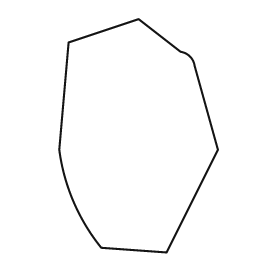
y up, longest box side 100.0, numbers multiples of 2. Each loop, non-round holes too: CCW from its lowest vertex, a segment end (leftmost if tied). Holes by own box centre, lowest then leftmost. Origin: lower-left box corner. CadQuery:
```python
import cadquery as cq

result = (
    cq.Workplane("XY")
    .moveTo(46.0, 0.0)
    .lineTo(68.0, 44.0)
    .lineTo(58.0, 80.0)
    .threePointArc((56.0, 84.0), (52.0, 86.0))
    .lineTo(34.0, 100.0)
    .lineTo(4.0, 90.0)
    .lineTo(0.0, 44.0)
    .threePointArc((6.0, 22.0), (18.0, 2.0))
    .close()
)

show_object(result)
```